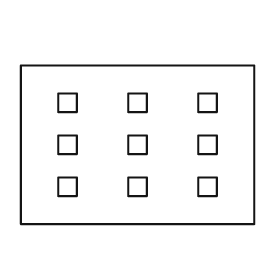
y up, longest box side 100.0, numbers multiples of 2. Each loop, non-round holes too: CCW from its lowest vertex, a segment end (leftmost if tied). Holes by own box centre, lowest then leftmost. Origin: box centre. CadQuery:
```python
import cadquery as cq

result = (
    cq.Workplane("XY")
    .moveTo(-50.0, -34.0)
    .lineTo(50.0, -34.0)
    .lineTo(50.0, 34.0)
    .lineTo(-50.0, 34.0)
    .close()
    .moveTo(-34.0, -22.0)
    .lineTo(-26.0, -22.0)
    .lineTo(-26.0, -14.0)
    .lineTo(-34.0, -14.0)
    .close()
    .moveTo(-4.0, -22.0)
    .lineTo(4.0, -22.0)
    .lineTo(4.0, -14.0)
    .lineTo(-4.0, -14.0)
    .close()
    .moveTo(26.0, -22.0)
    .lineTo(34.0, -22.0)
    .lineTo(34.0, -14.0)
    .lineTo(26.0, -14.0)
    .close()
    .moveTo(-34.0, -4.0)
    .lineTo(-26.0, -4.0)
    .lineTo(-26.0, 4.0)
    .lineTo(-34.0, 4.0)
    .close()
    .moveTo(-4.0, -4.0)
    .lineTo(4.0, -4.0)
    .lineTo(4.0, 4.0)
    .lineTo(-4.0, 4.0)
    .close()
    .moveTo(26.0, -4.0)
    .lineTo(34.0, -4.0)
    .lineTo(34.0, 4.0)
    .lineTo(26.0, 4.0)
    .close()
    .moveTo(-34.0, 14.0)
    .lineTo(-26.0, 14.0)
    .lineTo(-26.0, 22.0)
    .lineTo(-34.0, 22.0)
    .close()
    .moveTo(-4.0, 14.0)
    .lineTo(4.0, 14.0)
    .lineTo(4.0, 22.0)
    .lineTo(-4.0, 22.0)
    .close()
    .moveTo(26.0, 14.0)
    .lineTo(34.0, 14.0)
    .lineTo(34.0, 22.0)
    .lineTo(26.0, 22.0)
    .close()
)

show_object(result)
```